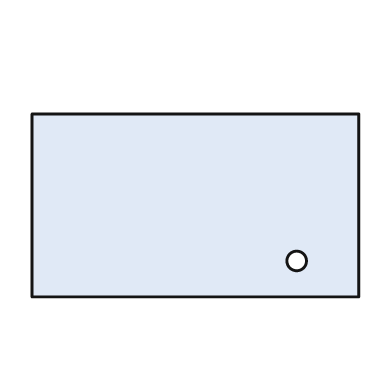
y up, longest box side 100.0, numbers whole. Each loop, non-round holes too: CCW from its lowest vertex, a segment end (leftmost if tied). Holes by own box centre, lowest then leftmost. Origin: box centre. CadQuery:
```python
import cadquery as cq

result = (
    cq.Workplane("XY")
    .moveTo(-50.0, -28.0)
    .lineTo(50.0, -28.0)
    .lineTo(50.0, 28.0)
    .lineTo(-50.0, 28.0)
    .close()
    .moveTo(31.0, -17.0)
    .circle(3.0)
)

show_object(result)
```